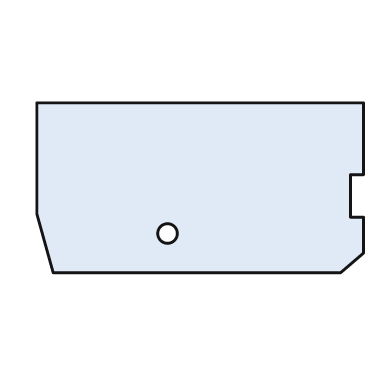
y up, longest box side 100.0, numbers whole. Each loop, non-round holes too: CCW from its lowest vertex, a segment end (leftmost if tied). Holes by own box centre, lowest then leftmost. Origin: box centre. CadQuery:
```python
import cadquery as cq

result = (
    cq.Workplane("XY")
    .moveTo(-45.0, -26.0)
    .lineTo(43.0, -26.0)
    .lineTo(50.0, -20.0)
    .lineTo(50.0, -9.0)
    .lineTo(46.0, -9.0)
    .lineTo(46.0, 4.0)
    .lineTo(50.0, 4.0)
    .lineTo(50.0, 26.0)
    .lineTo(-50.0, 26.0)
    .lineTo(-50.0, -8.0)
    .close()
    .moveTo(-10.0, -14.0)
    .circle(3.0)
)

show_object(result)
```